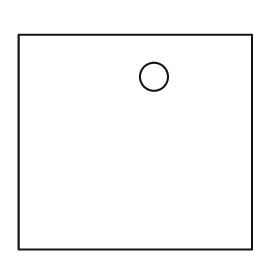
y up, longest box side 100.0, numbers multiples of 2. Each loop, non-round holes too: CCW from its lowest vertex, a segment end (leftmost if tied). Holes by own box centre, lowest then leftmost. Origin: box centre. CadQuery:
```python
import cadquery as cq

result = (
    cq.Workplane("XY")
    .moveTo(-50.0, -46.0)
    .lineTo(50.0, -46.0)
    .lineTo(50.0, 46.0)
    .lineTo(-50.0, 46.0)
    .close()
    .moveTo(8.0, 28.0)
    .circle(6.0)
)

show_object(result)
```